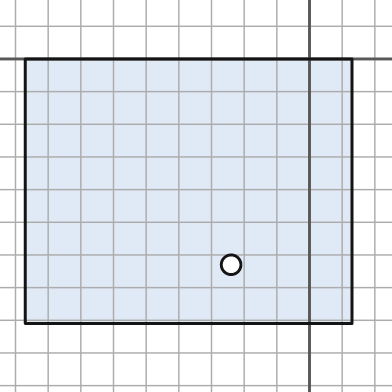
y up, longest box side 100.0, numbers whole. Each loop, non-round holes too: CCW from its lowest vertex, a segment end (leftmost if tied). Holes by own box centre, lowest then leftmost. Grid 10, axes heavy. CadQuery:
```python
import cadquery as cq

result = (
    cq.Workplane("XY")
    .moveTo(-87.0, -81.0)
    .lineTo(13.0, -81.0)
    .lineTo(13.0, 0.0)
    .lineTo(-87.0, 0.0)
    .close()
    .moveTo(-24.0, -63.0)
    .circle(3.0)
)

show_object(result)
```